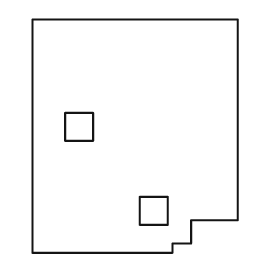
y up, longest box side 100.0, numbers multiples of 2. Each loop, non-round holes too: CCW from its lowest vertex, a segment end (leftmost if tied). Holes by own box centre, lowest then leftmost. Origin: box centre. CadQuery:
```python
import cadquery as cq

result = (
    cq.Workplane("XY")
    .moveTo(-44.0, -50.0)
    .lineTo(16.0, -50.0)
    .lineTo(16.0, -46.0)
    .lineTo(24.0, -46.0)
    .lineTo(24.0, -36.0)
    .lineTo(44.0, -36.0)
    .lineTo(44.0, 50.0)
    .lineTo(-44.0, 50.0)
    .close()
    .moveTo(2.0, -38.0)
    .lineTo(14.0, -38.0)
    .lineTo(14.0, -26.0)
    .lineTo(2.0, -26.0)
    .close()
    .moveTo(-30.0, -2.0)
    .lineTo(-18.0, -2.0)
    .lineTo(-18.0, 10.0)
    .lineTo(-30.0, 10.0)
    .close()
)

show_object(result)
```